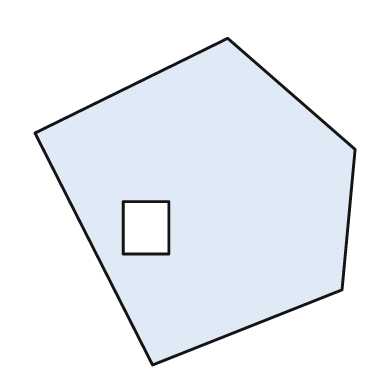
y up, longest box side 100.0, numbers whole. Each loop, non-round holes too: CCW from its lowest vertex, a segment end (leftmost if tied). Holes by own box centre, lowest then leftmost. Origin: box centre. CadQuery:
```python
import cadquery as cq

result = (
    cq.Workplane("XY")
    .moveTo(-13.0, -50.0)
    .lineTo(45.0, -27.0)
    .lineTo(49.0, 16.0)
    .lineTo(10.0, 50.0)
    .lineTo(-49.0, 21.0)
    .close()
    .moveTo(-22.0, -16.0)
    .lineTo(-8.0, -16.0)
    .lineTo(-8.0, 0.0)
    .lineTo(-22.0, 0.0)
    .close()
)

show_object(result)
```